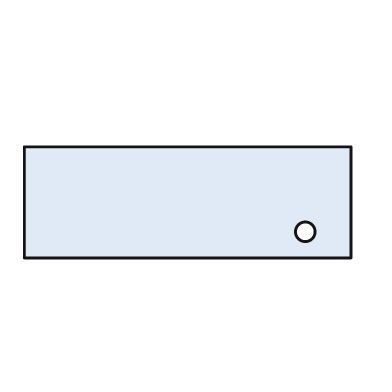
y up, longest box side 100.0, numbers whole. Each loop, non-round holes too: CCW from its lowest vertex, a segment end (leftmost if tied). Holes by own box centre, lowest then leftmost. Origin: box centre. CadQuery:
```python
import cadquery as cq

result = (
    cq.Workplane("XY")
    .moveTo(-50.0, -17.0)
    .lineTo(50.0, -17.0)
    .lineTo(50.0, 17.0)
    .lineTo(-50.0, 17.0)
    .close()
    .moveTo(36.0, -9.0)
    .circle(3.0)
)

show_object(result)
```